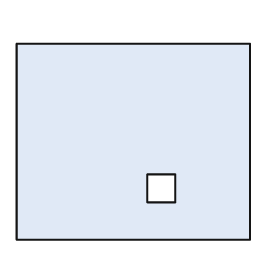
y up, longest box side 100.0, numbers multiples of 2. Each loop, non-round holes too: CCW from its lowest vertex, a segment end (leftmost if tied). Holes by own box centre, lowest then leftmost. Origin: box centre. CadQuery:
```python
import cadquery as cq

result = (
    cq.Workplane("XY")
    .moveTo(-50.0, -42.0)
    .lineTo(50.0, -42.0)
    .lineTo(50.0, 42.0)
    .lineTo(-50.0, 42.0)
    .close()
    .moveTo(6.0, -26.0)
    .lineTo(18.0, -26.0)
    .lineTo(18.0, -14.0)
    .lineTo(6.0, -14.0)
    .close()
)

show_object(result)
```